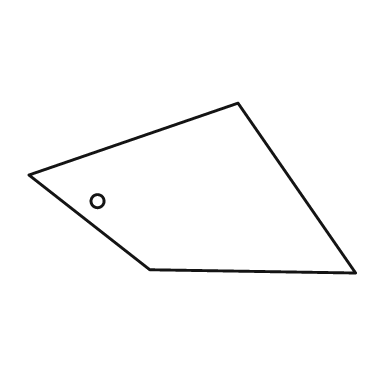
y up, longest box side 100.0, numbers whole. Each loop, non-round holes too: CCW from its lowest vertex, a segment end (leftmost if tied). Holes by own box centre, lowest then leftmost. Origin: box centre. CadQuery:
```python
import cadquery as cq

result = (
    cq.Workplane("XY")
    .moveTo(50.0, -26.0)
    .lineTo(14.0, 26.0)
    .lineTo(-50.0, 4.0)
    .lineTo(-13.0, -25.0)
    .close()
    .moveTo(-29.0, -4.0)
    .circle(2.0)
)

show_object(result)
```